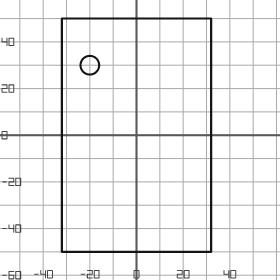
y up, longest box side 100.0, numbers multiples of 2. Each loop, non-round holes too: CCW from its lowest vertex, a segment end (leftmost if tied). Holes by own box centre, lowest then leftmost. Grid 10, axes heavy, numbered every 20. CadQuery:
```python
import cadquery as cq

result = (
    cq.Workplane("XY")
    .moveTo(-32.0, -50.0)
    .lineTo(32.0, -50.0)
    .lineTo(32.0, 50.0)
    .lineTo(-32.0, 50.0)
    .close()
    .moveTo(-20.0, 30.0)
    .circle(4.0)
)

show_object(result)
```